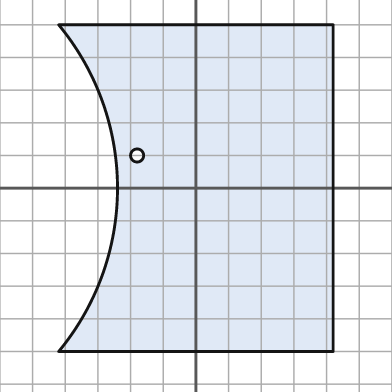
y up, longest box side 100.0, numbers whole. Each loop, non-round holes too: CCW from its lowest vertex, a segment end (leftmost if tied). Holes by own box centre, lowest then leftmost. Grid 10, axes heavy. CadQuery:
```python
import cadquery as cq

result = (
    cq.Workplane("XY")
    .moveTo(-42.0, -50.0)
    .lineTo(42.0, -50.0)
    .lineTo(42.0, 50.0)
    .lineTo(-42.0, 50.0)
    .threePointArc((-24.0, 0.0), (-42.0, -50.0))
    .close()
    .moveTo(-18.0, 10.0)
    .circle(2.0)
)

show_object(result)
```